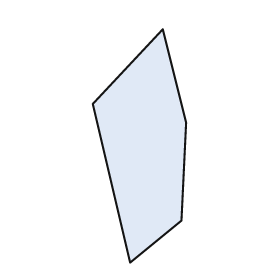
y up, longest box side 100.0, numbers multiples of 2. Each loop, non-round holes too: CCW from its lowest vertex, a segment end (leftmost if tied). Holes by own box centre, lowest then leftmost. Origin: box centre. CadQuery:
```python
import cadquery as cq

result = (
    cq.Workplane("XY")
    .moveTo(-4.0, -50.0)
    .lineTo(18.0, -32.0)
    .lineTo(20.0, 10.0)
    .lineTo(10.0, 50.0)
    .lineTo(-20.0, 18.0)
    .close()
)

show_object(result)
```